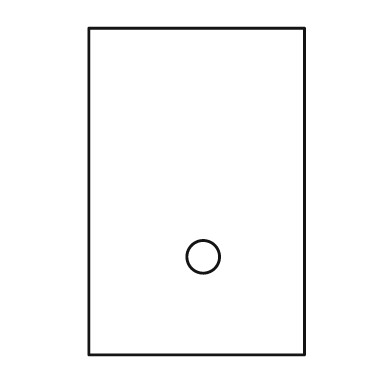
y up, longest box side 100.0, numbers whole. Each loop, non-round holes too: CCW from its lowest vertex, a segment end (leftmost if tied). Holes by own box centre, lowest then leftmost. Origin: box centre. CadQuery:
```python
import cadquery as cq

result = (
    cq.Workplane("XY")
    .moveTo(-33.0, -50.0)
    .lineTo(33.0, -50.0)
    .lineTo(33.0, 50.0)
    .lineTo(-33.0, 50.0)
    .close()
    .moveTo(2.0, -20.0)
    .circle(5.0)
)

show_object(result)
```